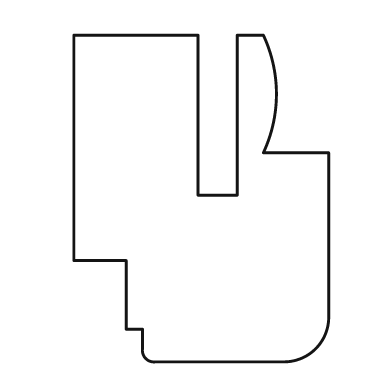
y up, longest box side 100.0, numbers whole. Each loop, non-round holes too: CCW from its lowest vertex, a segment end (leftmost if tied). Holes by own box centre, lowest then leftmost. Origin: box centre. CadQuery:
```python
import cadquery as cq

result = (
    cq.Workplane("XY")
    .moveTo(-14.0, -50.0)
    .lineTo(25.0, -50.0)
    .threePointArc((35.0, -46.0), (39.0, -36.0))
    .lineTo(39.0, 14.0)
    .lineTo(19.0, 14.0)
    .threePointArc((23.0, 32.0), (19.0, 50.0))
    .lineTo(11.0, 50.0)
    .lineTo(11.0, 1.0)
    .lineTo(-1.0, 1.0)
    .lineTo(-1.0, 50.0)
    .lineTo(-39.0, 50.0)
    .lineTo(-39.0, -19.0)
    .lineTo(-23.0, -19.0)
    .lineTo(-23.0, -40.0)
    .lineTo(-18.0, -40.0)
    .lineTo(-18.0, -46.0)
    .threePointArc((-17.0, -49.0), (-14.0, -50.0))
    .close()
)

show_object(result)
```